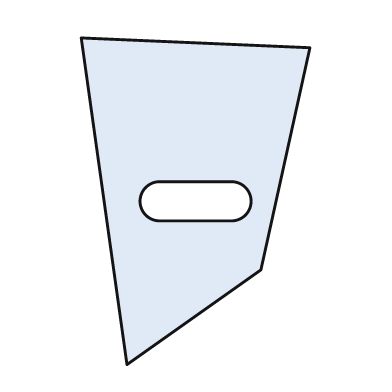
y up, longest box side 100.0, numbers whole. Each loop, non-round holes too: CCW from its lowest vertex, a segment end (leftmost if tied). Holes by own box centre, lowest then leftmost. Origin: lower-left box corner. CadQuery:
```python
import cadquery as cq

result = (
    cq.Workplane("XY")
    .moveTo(14.0, 0.0)
    .lineTo(55.0, 29.0)
    .lineTo(70.0, 97.0)
    .lineTo(0.0, 100.0)
    .close()
    .moveTo(24.0, 44.0)
    .lineTo(46.0, 44.0)
    .threePointArc((52.0, 50.0), (46.0, 56.0))
    .lineTo(24.0, 56.0)
    .threePointArc((18.0, 50.0), (24.0, 44.0))
    .close()
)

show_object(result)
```